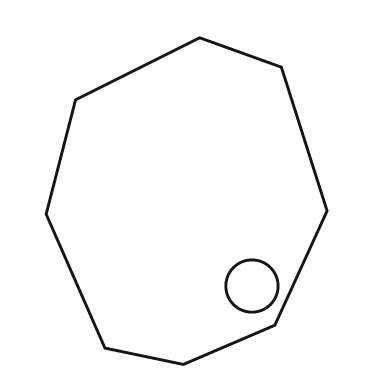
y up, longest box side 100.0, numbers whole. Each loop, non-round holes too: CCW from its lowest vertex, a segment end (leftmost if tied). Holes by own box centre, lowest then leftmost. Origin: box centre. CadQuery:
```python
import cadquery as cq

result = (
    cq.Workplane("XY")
    .moveTo(-1.0, -50.0)
    .lineTo(27.0, -38.0)
    .lineTo(43.0, -3.0)
    .lineTo(29.0, 41.0)
    .lineTo(4.0, 50.0)
    .lineTo(-34.0, 31.0)
    .lineTo(-43.0, -4.0)
    .lineTo(-25.0, -45.0)
    .close()
    .moveTo(20.0, -26.0)
    .circle(8.0)
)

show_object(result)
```